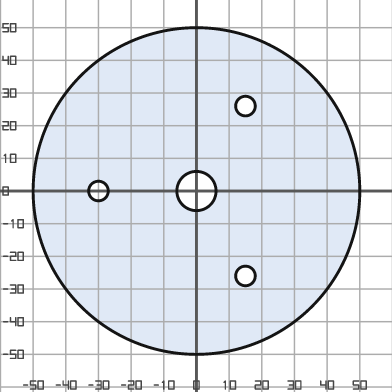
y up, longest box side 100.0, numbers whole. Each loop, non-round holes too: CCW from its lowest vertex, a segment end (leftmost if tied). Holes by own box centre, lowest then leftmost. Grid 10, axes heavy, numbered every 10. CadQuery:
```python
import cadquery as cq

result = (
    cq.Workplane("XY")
    .moveTo(0.0, 0.0)
    .circle(50.0)
    .moveTo(15.0, -26.0)
    .circle(3.0)
    .moveTo(-30.0, 0.0)
    .circle(3.0)
    .moveTo(0.0, 0.0)
    .circle(6.0)
    .moveTo(15.0, 26.0)
    .circle(3.0)
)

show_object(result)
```